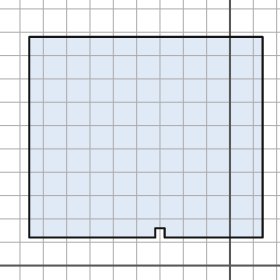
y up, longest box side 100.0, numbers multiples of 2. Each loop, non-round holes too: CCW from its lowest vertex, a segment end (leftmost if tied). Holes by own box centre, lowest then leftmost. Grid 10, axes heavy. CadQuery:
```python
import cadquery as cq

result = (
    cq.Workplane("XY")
    .moveTo(-86.0, 12.0)
    .lineTo(-32.0, 12.0)
    .lineTo(-32.0, 16.0)
    .lineTo(-28.0, 16.0)
    .lineTo(-28.0, 12.0)
    .lineTo(14.0, 12.0)
    .lineTo(14.0, 98.0)
    .lineTo(-86.0, 98.0)
    .close()
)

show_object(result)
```